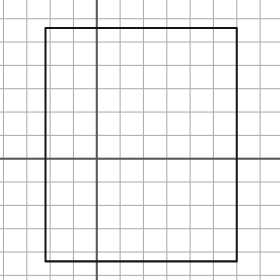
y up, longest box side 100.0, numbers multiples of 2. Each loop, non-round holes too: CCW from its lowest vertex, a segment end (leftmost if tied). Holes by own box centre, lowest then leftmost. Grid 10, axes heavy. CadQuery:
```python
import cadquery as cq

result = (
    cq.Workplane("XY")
    .moveTo(-22.0, -44.0)
    .lineTo(60.0, -44.0)
    .lineTo(60.0, 56.0)
    .lineTo(-22.0, 56.0)
    .close()
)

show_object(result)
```